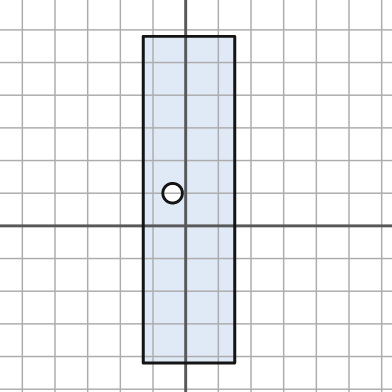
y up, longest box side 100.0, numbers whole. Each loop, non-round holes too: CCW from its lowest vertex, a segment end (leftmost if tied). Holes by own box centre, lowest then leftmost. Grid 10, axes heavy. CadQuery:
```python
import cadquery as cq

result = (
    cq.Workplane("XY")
    .moveTo(-13.0, -42.0)
    .lineTo(15.0, -42.0)
    .lineTo(15.0, 58.0)
    .lineTo(-13.0, 58.0)
    .close()
    .moveTo(-4.0, 10.0)
    .circle(3.0)
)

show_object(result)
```